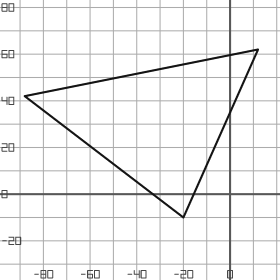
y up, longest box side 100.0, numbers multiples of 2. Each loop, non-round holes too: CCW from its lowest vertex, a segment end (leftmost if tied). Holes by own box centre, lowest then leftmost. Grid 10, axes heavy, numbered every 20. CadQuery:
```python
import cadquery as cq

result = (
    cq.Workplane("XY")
    .moveTo(-20.0, -10.0)
    .lineTo(12.0, 62.0)
    .lineTo(-88.0, 42.0)
    .close()
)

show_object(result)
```